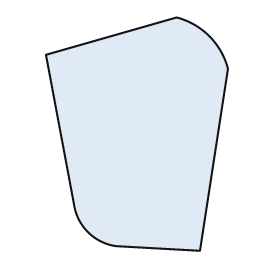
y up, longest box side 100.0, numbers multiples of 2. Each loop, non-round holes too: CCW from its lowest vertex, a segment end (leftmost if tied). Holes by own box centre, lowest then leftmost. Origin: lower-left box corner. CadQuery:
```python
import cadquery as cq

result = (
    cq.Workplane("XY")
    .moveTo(66.0, 0.0)
    .lineTo(78.0, 78.0)
    .threePointArc((70.0, 92.0), (56.0, 100.0))
    .lineTo(0.0, 84.0)
    .lineTo(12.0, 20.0)
    .threePointArc((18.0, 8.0), (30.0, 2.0))
    .close()
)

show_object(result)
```